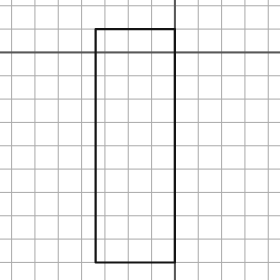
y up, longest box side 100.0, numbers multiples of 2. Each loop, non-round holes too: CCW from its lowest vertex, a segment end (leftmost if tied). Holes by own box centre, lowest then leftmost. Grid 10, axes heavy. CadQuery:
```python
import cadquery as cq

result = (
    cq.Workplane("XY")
    .moveTo(-34.0, -90.0)
    .lineTo(0.0, -90.0)
    .lineTo(0.0, 10.0)
    .lineTo(-34.0, 10.0)
    .close()
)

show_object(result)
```